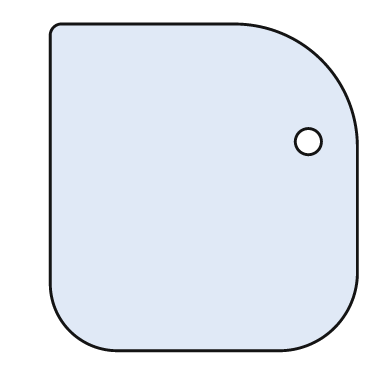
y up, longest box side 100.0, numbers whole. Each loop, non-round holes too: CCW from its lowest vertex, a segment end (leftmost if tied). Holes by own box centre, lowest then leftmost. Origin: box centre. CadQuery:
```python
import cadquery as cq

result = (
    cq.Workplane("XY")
    .moveTo(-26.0, -50.0)
    .lineTo(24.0, -50.0)
    .threePointArc((40.0, -43.0), (47.0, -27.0))
    .lineTo(47.0, 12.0)
    .threePointArc((36.0, 39.0), (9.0, 50.0))
    .lineTo(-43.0, 50.0)
    .threePointArc((-46.0, 49.0), (-47.0, 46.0))
    .lineTo(-47.0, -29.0)
    .threePointArc((-41.0, -44.0), (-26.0, -50.0))
    .close()
    .moveTo(32.0, 14.0)
    .circle(4.0)
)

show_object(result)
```